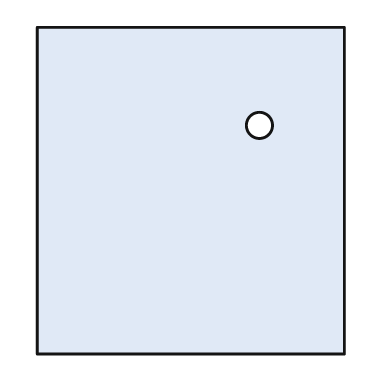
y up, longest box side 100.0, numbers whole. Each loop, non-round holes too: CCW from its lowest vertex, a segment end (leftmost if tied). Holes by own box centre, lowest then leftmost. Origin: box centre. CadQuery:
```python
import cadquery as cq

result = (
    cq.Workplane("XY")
    .moveTo(-47.0, -50.0)
    .lineTo(47.0, -50.0)
    .lineTo(47.0, 50.0)
    .lineTo(-47.0, 50.0)
    .close()
    .moveTo(21.0, 20.0)
    .circle(4.0)
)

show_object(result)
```